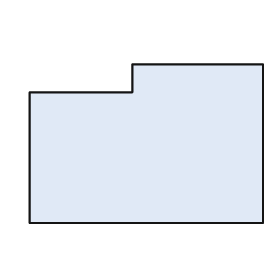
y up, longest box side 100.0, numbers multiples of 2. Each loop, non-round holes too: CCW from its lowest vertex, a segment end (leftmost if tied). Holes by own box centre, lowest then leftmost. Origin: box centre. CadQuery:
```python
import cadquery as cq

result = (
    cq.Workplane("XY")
    .moveTo(-50.0, -34.0)
    .lineTo(50.0, -34.0)
    .lineTo(50.0, 34.0)
    .lineTo(-6.0, 34.0)
    .lineTo(-6.0, 22.0)
    .lineTo(-50.0, 22.0)
    .close()
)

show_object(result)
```